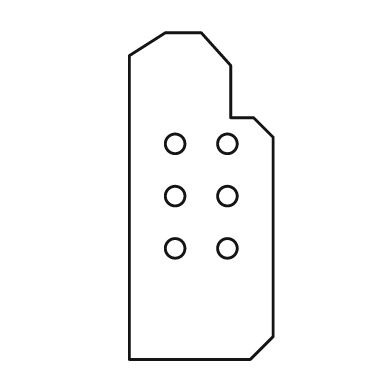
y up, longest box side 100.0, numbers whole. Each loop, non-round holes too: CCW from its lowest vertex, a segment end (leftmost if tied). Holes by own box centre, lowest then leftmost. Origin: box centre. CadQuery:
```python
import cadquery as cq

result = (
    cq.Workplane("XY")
    .moveTo(-22.0, -50.0)
    .lineTo(15.0, -50.0)
    .lineTo(22.0, -43.0)
    .lineTo(22.0, 18.0)
    .lineTo(16.0, 24.0)
    .lineTo(9.0, 24.0)
    .lineTo(9.0, 40.0)
    .lineTo(0.0, 50.0)
    .lineTo(-11.0, 50.0)
    .lineTo(-22.0, 43.0)
    .close()
    .moveTo(-8.0, -16.0)
    .circle(3.0)
    .moveTo(8.0, -16.0)
    .circle(3.0)
    .moveTo(-8.0, 0.0)
    .circle(3.0)
    .moveTo(8.0, 0.0)
    .circle(3.0)
    .moveTo(-8.0, 16.0)
    .circle(3.0)
    .moveTo(8.0, 16.0)
    .circle(3.0)
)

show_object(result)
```